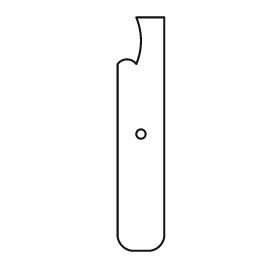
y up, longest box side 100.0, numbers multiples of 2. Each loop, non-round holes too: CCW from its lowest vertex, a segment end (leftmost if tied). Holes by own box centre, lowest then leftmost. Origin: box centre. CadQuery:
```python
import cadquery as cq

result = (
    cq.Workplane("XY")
    .moveTo(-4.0, -50.0)
    .lineTo(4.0, -50.0)
    .threePointArc((8.0, -48.0), (10.0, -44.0))
    .lineTo(10.0, 50.0)
    .lineTo(-2.0, 50.0)
    .threePointArc((0.0, 40.0), (-2.0, 30.0))
    .threePointArc((-6.0, 32.0), (-10.0, 30.0))
    .lineTo(-10.0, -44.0)
    .threePointArc((-8.0, -48.0), (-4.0, -50.0))
    .close()
    .moveTo(0.0, 0.0)
    .circle(2.0)
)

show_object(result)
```